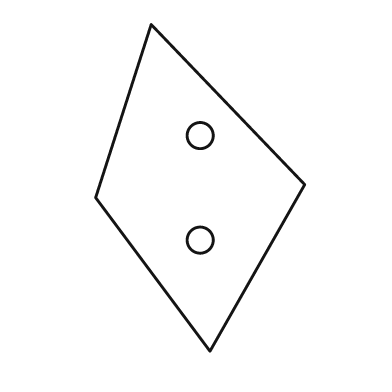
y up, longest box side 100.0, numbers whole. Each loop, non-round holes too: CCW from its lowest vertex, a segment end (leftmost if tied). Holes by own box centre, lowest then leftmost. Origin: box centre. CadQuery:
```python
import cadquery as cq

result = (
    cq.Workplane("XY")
    .moveTo(3.0, -50.0)
    .lineTo(32.0, 1.0)
    .lineTo(-15.0, 50.0)
    .lineTo(-32.0, -3.0)
    .close()
    .moveTo(0.0, -16.0)
    .circle(4.0)
    .moveTo(0.0, 16.0)
    .circle(4.0)
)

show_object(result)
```